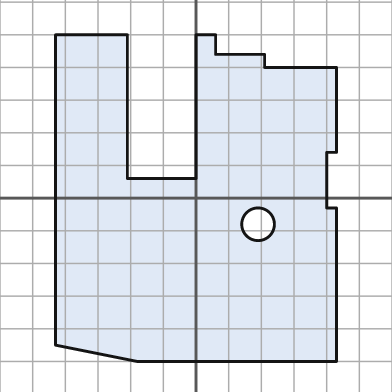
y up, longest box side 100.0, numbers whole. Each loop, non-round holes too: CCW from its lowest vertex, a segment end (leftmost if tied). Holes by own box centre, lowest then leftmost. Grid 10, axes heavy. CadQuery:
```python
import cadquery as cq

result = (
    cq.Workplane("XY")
    .moveTo(-18.0, -50.0)
    .lineTo(43.0, -50.0)
    .lineTo(43.0, -3.0)
    .lineTo(40.0, -3.0)
    .lineTo(40.0, 14.0)
    .lineTo(43.0, 14.0)
    .lineTo(43.0, 40.0)
    .lineTo(21.0, 40.0)
    .lineTo(21.0, 44.0)
    .lineTo(6.0, 44.0)
    .lineTo(6.0, 50.0)
    .lineTo(0.0, 50.0)
    .lineTo(0.0, 6.0)
    .lineTo(-21.0, 6.0)
    .lineTo(-21.0, 50.0)
    .lineTo(-43.0, 50.0)
    .lineTo(-43.0, -45.0)
    .close()
    .moveTo(19.0, -8.0)
    .circle(5.0)
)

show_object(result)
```